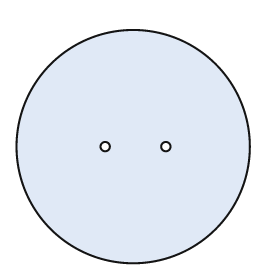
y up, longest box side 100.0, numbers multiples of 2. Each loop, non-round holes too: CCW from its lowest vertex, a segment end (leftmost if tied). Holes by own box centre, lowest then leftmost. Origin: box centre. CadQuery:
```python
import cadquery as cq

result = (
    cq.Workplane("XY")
    .moveTo(0.0, 0.0)
    .circle(50.0)
    .moveTo(-12.0, 0.0)
    .circle(2.0)
    .moveTo(14.0, 0.0)
    .circle(2.0)
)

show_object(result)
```